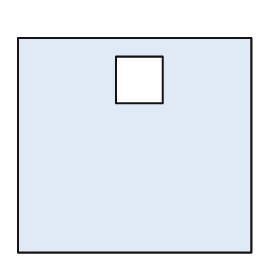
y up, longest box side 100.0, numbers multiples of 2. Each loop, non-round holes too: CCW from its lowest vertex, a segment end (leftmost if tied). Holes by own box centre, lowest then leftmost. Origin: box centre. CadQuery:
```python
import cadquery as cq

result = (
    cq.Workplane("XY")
    .moveTo(-50.0, -46.0)
    .lineTo(50.0, -46.0)
    .lineTo(50.0, 46.0)
    .lineTo(-50.0, 46.0)
    .close()
    .moveTo(-8.0, 18.0)
    .lineTo(12.0, 18.0)
    .lineTo(12.0, 38.0)
    .lineTo(-8.0, 38.0)
    .close()
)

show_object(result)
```